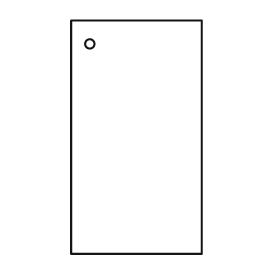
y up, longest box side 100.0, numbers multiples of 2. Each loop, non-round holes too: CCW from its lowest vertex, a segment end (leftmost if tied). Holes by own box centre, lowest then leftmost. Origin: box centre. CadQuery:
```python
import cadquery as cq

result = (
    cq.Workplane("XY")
    .moveTo(-28.0, -50.0)
    .lineTo(28.0, -50.0)
    .lineTo(28.0, 50.0)
    .lineTo(-28.0, 50.0)
    .close()
    .moveTo(-20.0, 40.0)
    .circle(2.0)
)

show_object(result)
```